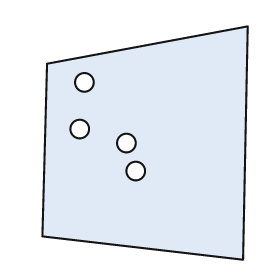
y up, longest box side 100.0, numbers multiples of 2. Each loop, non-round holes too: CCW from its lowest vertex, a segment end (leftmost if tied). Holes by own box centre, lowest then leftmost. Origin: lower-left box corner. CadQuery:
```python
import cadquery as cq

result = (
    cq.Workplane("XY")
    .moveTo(86.0, 0.0)
    .lineTo(88.0, 100.0)
    .lineTo(2.0, 84.0)
    .lineTo(0.0, 10.0)
    .close()
    .moveTo(40.0, 38.0)
    .circle(4.0)
    .moveTo(36.0, 50.0)
    .circle(4.0)
    .moveTo(16.0, 56.0)
    .circle(4.0)
    .moveTo(18.0, 76.0)
    .circle(4.0)
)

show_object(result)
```